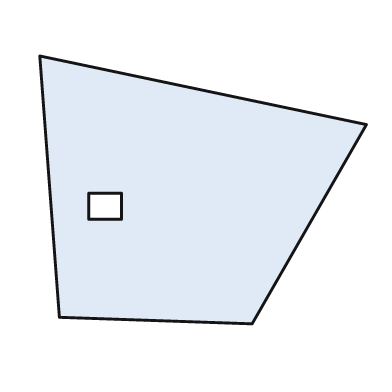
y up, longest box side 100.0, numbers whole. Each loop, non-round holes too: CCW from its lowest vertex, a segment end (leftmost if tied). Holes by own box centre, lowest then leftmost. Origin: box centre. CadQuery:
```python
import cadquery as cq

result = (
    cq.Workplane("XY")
    .moveTo(15.0, -41.0)
    .lineTo(50.0, 20.0)
    .lineTo(-50.0, 41.0)
    .lineTo(-44.0, -39.0)
    .close()
    .moveTo(-35.0, -9.0)
    .lineTo(-25.0, -9.0)
    .lineTo(-25.0, -1.0)
    .lineTo(-35.0, -1.0)
    .close()
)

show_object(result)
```